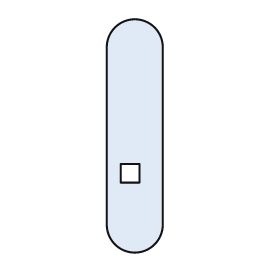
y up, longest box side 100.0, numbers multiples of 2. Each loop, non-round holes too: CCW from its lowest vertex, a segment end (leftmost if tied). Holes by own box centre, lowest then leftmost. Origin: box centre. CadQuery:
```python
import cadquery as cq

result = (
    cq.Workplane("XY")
    .moveTo(-12.0, -38.0)
    .threePointArc((0.0, -50.0), (12.0, -38.0))
    .lineTo(12.0, 38.0)
    .threePointArc((0.0, 50.0), (-12.0, 38.0))
    .close()
    .moveTo(-6.0, -20.0)
    .lineTo(2.0, -20.0)
    .lineTo(2.0, -12.0)
    .lineTo(-6.0, -12.0)
    .close()
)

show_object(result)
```